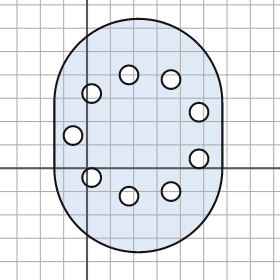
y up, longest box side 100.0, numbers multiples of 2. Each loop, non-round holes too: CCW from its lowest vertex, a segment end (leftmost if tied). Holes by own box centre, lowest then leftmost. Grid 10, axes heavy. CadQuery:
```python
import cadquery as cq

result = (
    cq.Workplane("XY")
    .moveTo(-14.0, 0.0)
    .threePointArc((22.0, -36.0), (58.0, 0.0))
    .lineTo(58.0, 28.0)
    .threePointArc((22.0, 64.0), (-14.0, 28.0))
    .close()
    .moveTo(18.0, -12.0)
    .circle(4.0)
    .moveTo(36.0, -10.0)
    .circle(4.0)
    .moveTo(2.0, -4.0)
    .circle(4.0)
    .moveTo(48.0, 4.0)
    .circle(4.0)
    .moveTo(-6.0, 14.0)
    .circle(4.0)
    .moveTo(48.0, 24.0)
    .circle(4.0)
    .moveTo(2.0, 32.0)
    .circle(4.0)
    .moveTo(36.0, 38.0)
    .circle(4.0)
    .moveTo(18.0, 40.0)
    .circle(4.0)
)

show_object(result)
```